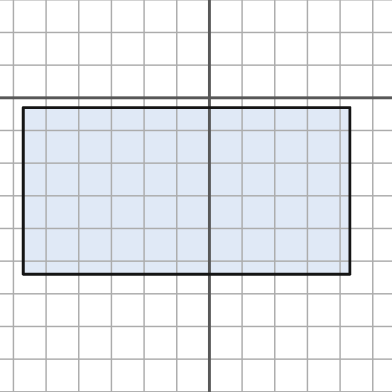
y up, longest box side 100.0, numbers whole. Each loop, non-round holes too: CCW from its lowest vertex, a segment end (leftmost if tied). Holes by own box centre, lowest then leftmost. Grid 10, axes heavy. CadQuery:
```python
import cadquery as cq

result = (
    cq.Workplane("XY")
    .moveTo(-57.0, -54.0)
    .lineTo(43.0, -54.0)
    .lineTo(43.0, -3.0)
    .lineTo(-57.0, -3.0)
    .close()
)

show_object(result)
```